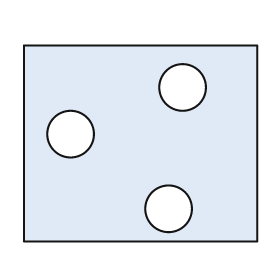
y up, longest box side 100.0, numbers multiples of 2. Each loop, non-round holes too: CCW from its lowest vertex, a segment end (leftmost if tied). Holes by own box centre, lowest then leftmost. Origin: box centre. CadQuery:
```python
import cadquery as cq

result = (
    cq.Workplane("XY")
    .moveTo(-50.0, -42.0)
    .lineTo(50.0, -42.0)
    .lineTo(50.0, 42.0)
    .lineTo(-50.0, 42.0)
    .close()
    .moveTo(12.0, -28.0)
    .circle(10.0)
    .moveTo(-30.0, 4.0)
    .circle(10.0)
    .moveTo(18.0, 24.0)
    .circle(10.0)
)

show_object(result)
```